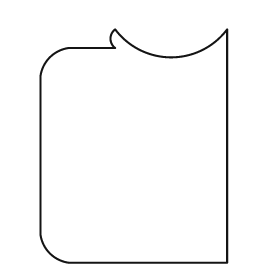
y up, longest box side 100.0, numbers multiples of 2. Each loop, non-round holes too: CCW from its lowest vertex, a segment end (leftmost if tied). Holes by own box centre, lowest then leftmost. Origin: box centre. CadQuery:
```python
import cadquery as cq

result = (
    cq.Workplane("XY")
    .moveTo(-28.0, -50.0)
    .lineTo(40.0, -50.0)
    .lineTo(40.0, 50.0)
    .threePointArc((16.0, 38.0), (-8.0, 50.0))
    .threePointArc((-10.0, 46.0), (-8.0, 42.0))
    .lineTo(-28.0, 42.0)
    .threePointArc((-36.0, 38.0), (-40.0, 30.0))
    .lineTo(-40.0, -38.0)
    .threePointArc((-36.0, -46.0), (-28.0, -50.0))
    .close()
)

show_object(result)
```